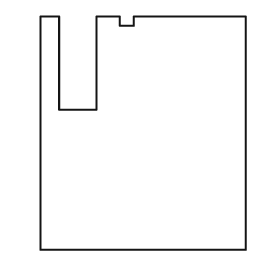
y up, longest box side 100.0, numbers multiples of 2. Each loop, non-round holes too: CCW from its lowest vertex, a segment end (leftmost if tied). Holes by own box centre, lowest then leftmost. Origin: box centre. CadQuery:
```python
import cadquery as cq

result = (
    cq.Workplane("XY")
    .moveTo(-44.0, -50.0)
    .lineTo(44.0, -50.0)
    .lineTo(44.0, 50.0)
    .lineTo(-4.0, 50.0)
    .lineTo(-4.0, 46.0)
    .lineTo(-10.0, 46.0)
    .lineTo(-10.0, 50.0)
    .lineTo(-20.0, 50.0)
    .lineTo(-20.0, 10.0)
    .lineTo(-36.0, 10.0)
    .lineTo(-36.0, 50.0)
    .lineTo(-44.0, 50.0)
    .close()
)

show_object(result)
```